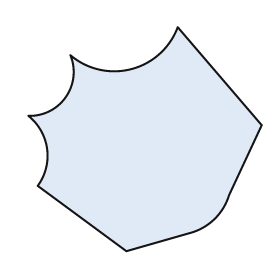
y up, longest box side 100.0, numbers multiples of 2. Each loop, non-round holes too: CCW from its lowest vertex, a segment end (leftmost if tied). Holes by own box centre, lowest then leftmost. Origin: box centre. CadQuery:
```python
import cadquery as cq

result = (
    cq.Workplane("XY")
    .moveTo(-8.0, -48.0)
    .lineTo(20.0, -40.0)
    .threePointArc((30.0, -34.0), (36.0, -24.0))
    .lineTo(50.0, 6.0)
    .lineTo(14.0, 48.0)
    .threePointArc((-6.0, 30.0), (-32.0, 36.0))
    .threePointArc((-34.0, 18.0), (-50.0, 10.0))
    .threePointArc((-42.0, -4.0), (-46.0, -20.0))
    .close()
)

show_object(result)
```